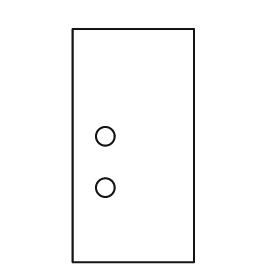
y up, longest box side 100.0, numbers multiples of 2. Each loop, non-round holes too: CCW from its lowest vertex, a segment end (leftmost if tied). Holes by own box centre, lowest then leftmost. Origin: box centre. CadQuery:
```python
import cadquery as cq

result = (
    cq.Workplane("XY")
    .moveTo(-26.0, -50.0)
    .lineTo(26.0, -50.0)
    .lineTo(26.0, 50.0)
    .lineTo(-26.0, 50.0)
    .close()
    .moveTo(-12.0, -18.0)
    .circle(4.0)
    .moveTo(-12.0, 4.0)
    .circle(4.0)
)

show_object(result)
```